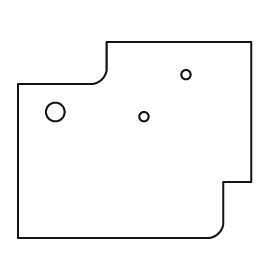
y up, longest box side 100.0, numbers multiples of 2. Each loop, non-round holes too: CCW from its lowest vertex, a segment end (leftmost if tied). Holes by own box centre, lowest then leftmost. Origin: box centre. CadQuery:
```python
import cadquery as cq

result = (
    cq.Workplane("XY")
    .moveTo(-50.0, -42.0)
    .lineTo(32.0, -42.0)
    .threePointArc((36.0, -40.0), (38.0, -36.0))
    .lineTo(38.0, -18.0)
    .lineTo(50.0, -18.0)
    .lineTo(50.0, 42.0)
    .lineTo(-12.0, 42.0)
    .lineTo(-12.0, 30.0)
    .threePointArc((-14.0, 26.0), (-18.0, 24.0))
    .lineTo(-50.0, 24.0)
    .close()
    .moveTo(4.0, 10.0)
    .circle(2.0)
    .moveTo(-34.0, 12.0)
    .circle(4.0)
    .moveTo(22.0, 28.0)
    .circle(2.0)
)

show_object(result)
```